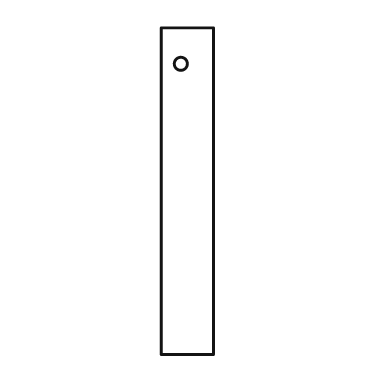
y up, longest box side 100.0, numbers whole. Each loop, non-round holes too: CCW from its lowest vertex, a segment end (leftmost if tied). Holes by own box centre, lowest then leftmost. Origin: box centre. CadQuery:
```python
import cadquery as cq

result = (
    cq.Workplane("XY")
    .moveTo(-8.0, -50.0)
    .lineTo(8.0, -50.0)
    .lineTo(8.0, 50.0)
    .lineTo(-8.0, 50.0)
    .close()
    .moveTo(-2.0, 39.0)
    .circle(2.0)
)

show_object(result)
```